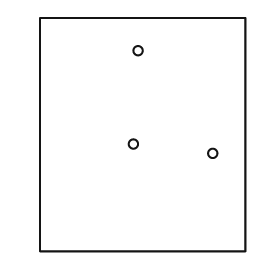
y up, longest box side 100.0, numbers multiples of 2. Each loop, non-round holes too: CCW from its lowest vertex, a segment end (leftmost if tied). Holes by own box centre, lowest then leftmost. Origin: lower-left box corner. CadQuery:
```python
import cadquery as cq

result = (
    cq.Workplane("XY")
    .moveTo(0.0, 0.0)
    .lineTo(88.0, 0.0)
    .lineTo(88.0, 100.0)
    .lineTo(0.0, 100.0)
    .close()
    .moveTo(74.0, 42.0)
    .circle(2.0)
    .moveTo(40.0, 46.0)
    .circle(2.0)
    .moveTo(42.0, 86.0)
    .circle(2.0)
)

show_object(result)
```